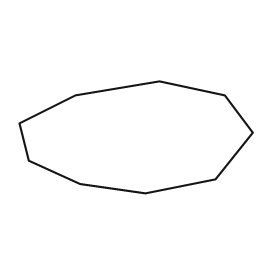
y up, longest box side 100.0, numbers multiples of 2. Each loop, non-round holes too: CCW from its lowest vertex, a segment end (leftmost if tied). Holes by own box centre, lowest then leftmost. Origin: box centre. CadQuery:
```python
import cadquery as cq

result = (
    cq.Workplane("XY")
    .moveTo(4.0, -24.0)
    .lineTo(34.0, -18.0)
    .lineTo(50.0, 2.0)
    .lineTo(38.0, 18.0)
    .lineTo(10.0, 24.0)
    .lineTo(-26.0, 18.0)
    .lineTo(-50.0, 6.0)
    .lineTo(-46.0, -10.0)
    .lineTo(-24.0, -20.0)
    .close()
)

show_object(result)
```